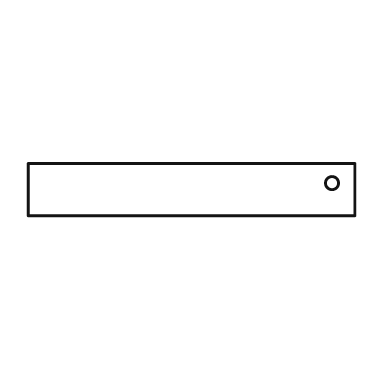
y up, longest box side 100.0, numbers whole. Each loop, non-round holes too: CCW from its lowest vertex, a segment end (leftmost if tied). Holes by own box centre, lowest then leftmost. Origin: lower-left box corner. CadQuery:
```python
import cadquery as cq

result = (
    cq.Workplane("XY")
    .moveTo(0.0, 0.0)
    .lineTo(100.0, 0.0)
    .lineTo(100.0, 16.0)
    .lineTo(0.0, 16.0)
    .close()
    .moveTo(93.0, 10.0)
    .circle(2.0)
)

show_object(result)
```